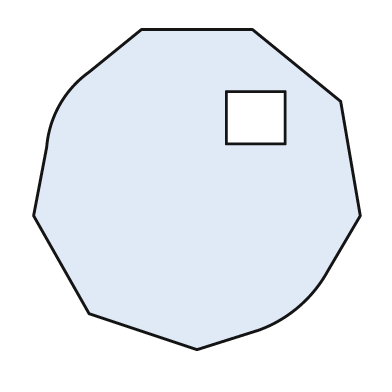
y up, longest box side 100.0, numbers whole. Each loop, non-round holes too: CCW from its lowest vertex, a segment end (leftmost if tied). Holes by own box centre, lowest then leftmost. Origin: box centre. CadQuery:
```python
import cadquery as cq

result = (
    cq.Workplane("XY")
    .moveTo(0.0, -49.0)
    .lineTo(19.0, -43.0)
    .threePointArc((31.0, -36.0), (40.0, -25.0))
    .lineTo(50.0, -8.0)
    .lineTo(44.0, 27.0)
    .lineTo(17.0, 49.0)
    .lineTo(-17.0, 49.0)
    .lineTo(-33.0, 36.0)
    .threePointArc((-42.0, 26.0), (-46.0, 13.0))
    .lineTo(-50.0, -8.0)
    .lineTo(-33.0, -38.0)
    .close()
    .moveTo(9.0, 14.0)
    .lineTo(27.0, 14.0)
    .lineTo(27.0, 30.0)
    .lineTo(9.0, 30.0)
    .close()
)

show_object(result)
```